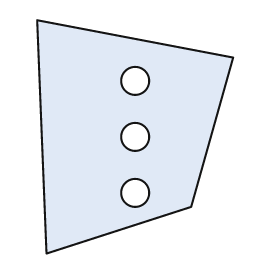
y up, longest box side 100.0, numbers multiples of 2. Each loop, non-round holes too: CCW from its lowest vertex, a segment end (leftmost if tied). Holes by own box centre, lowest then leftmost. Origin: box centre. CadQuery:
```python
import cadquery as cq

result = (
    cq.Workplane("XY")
    .moveTo(-38.0, -50.0)
    .lineTo(24.0, -30.0)
    .lineTo(42.0, 34.0)
    .lineTo(-42.0, 50.0)
    .close()
    .moveTo(0.0, -24.0)
    .circle(6.0)
    .moveTo(0.0, 0.0)
    .circle(6.0)
    .moveTo(0.0, 24.0)
    .circle(6.0)
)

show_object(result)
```